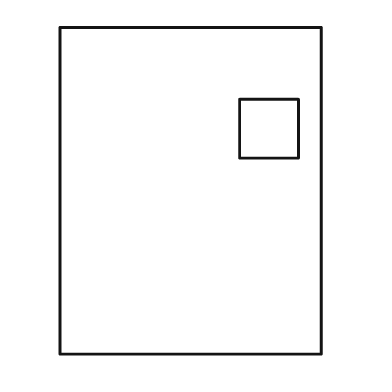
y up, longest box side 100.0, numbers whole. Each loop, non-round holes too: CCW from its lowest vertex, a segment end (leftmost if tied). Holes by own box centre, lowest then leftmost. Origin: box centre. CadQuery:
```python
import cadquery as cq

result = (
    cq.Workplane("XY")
    .moveTo(-40.0, -50.0)
    .lineTo(40.0, -50.0)
    .lineTo(40.0, 50.0)
    .lineTo(-40.0, 50.0)
    .close()
    .moveTo(15.0, 10.0)
    .lineTo(33.0, 10.0)
    .lineTo(33.0, 28.0)
    .lineTo(15.0, 28.0)
    .close()
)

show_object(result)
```